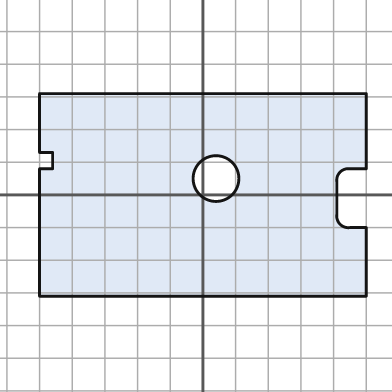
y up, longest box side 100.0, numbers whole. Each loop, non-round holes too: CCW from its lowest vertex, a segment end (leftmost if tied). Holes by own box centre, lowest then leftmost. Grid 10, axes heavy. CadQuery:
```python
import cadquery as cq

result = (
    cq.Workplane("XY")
    .moveTo(-50.0, -31.0)
    .lineTo(50.0, -31.0)
    .lineTo(50.0, -10.0)
    .lineTo(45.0, -10.0)
    .threePointArc((42.0, -9.0), (41.0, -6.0))
    .lineTo(41.0, 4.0)
    .threePointArc((42.0, 7.0), (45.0, 8.0))
    .lineTo(50.0, 8.0)
    .lineTo(50.0, 31.0)
    .lineTo(-50.0, 31.0)
    .lineTo(-50.0, 13.0)
    .lineTo(-46.0, 13.0)
    .lineTo(-46.0, 8.0)
    .lineTo(-50.0, 8.0)
    .close()
    .moveTo(4.0, 5.0)
    .circle(7.0)
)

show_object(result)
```